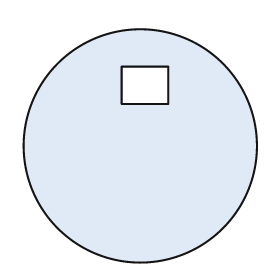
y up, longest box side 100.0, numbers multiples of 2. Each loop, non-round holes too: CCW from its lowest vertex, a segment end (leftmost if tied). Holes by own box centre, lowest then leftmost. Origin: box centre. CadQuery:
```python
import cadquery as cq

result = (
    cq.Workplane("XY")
    .moveTo(0.0, 0.0)
    .circle(50.0)
    .moveTo(-8.0, 18.0)
    .lineTo(12.0, 18.0)
    .lineTo(12.0, 34.0)
    .lineTo(-8.0, 34.0)
    .close()
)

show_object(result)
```